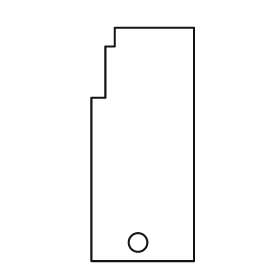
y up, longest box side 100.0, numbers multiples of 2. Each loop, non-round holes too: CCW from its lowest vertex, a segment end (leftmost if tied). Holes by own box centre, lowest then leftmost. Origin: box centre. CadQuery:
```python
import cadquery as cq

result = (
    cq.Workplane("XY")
    .moveTo(-22.0, -50.0)
    .lineTo(22.0, -50.0)
    .lineTo(22.0, 50.0)
    .lineTo(-12.0, 50.0)
    .lineTo(-12.0, 42.0)
    .lineTo(-16.0, 42.0)
    .lineTo(-16.0, 20.0)
    .lineTo(-22.0, 20.0)
    .close()
    .moveTo(-2.0, -42.0)
    .circle(4.0)
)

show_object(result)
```